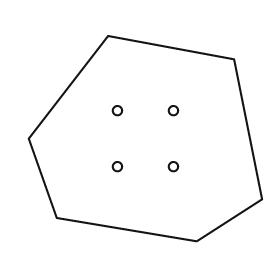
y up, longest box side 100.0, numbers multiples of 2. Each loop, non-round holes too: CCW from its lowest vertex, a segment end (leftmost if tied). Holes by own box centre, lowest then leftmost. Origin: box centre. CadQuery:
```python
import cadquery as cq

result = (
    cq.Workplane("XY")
    .moveTo(22.0, -44.0)
    .lineTo(50.0, -26.0)
    .lineTo(38.0, 34.0)
    .lineTo(-16.0, 44.0)
    .lineTo(-50.0, 0.0)
    .lineTo(-38.0, -34.0)
    .close()
    .moveTo(-12.0, -12.0)
    .circle(2.0)
    .moveTo(12.0, -12.0)
    .circle(2.0)
    .moveTo(-12.0, 12.0)
    .circle(2.0)
    .moveTo(12.0, 12.0)
    .circle(2.0)
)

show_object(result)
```